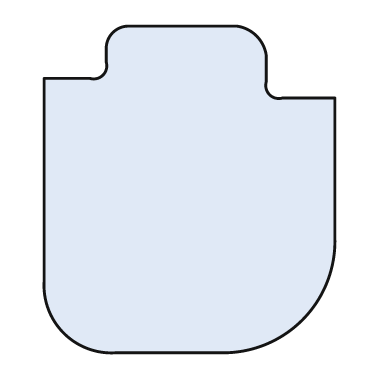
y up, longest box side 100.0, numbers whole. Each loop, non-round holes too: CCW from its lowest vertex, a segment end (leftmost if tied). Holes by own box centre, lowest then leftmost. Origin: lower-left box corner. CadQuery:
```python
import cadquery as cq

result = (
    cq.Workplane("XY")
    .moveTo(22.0, 0.0)
    .lineTo(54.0, 0.0)
    .threePointArc((79.0, 10.0), (89.0, 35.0))
    .lineTo(89.0, 78.0)
    .lineTo(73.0, 78.0)
    .threePointArc((69.0, 79.0), (68.0, 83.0))
    .lineTo(68.0, 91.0)
    .threePointArc((65.0, 97.0), (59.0, 100.0))
    .lineTo(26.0, 100.0)
    .threePointArc((21.0, 98.0), (19.0, 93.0))
    .lineTo(19.0, 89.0)
    .threePointArc((18.0, 85.0), (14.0, 84.0))
    .lineTo(0.0, 84.0)
    .lineTo(0.0, 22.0)
    .threePointArc((6.0, 6.0), (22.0, 0.0))
    .close()
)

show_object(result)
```